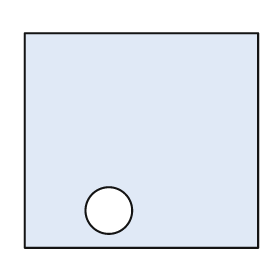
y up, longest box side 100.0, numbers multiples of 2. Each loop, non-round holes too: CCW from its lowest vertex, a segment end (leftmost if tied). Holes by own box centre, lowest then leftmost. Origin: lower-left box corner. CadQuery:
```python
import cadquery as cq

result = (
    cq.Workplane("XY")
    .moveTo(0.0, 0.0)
    .lineTo(100.0, 0.0)
    .lineTo(100.0, 92.0)
    .lineTo(0.0, 92.0)
    .close()
    .moveTo(36.0, 16.0)
    .circle(10.0)
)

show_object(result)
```